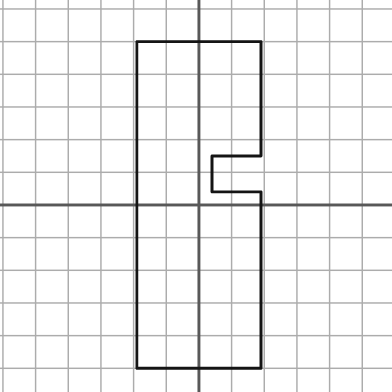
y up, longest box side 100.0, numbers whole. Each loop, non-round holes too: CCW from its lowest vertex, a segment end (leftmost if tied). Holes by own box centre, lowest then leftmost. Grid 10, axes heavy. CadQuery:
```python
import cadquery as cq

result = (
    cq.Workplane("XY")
    .moveTo(-19.0, -50.0)
    .lineTo(19.0, -50.0)
    .lineTo(19.0, 4.0)
    .lineTo(4.0, 4.0)
    .lineTo(4.0, 15.0)
    .lineTo(19.0, 15.0)
    .lineTo(19.0, 50.0)
    .lineTo(-19.0, 50.0)
    .close()
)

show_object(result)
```